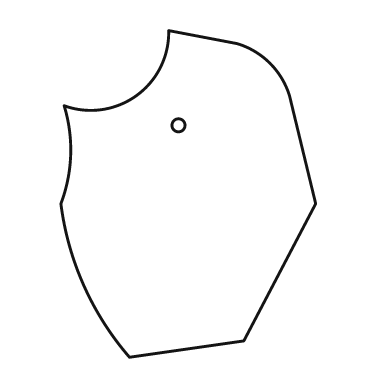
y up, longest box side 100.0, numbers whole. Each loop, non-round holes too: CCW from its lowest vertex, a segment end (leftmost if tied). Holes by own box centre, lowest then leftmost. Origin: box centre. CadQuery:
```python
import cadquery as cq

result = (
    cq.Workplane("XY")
    .moveTo(-18.0, -50.0)
    .lineTo(17.0, -45.0)
    .lineTo(39.0, -3.0)
    .lineTo(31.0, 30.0)
    .threePointArc((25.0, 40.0), (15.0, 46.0))
    .lineTo(-6.0, 50.0)
    .threePointArc((-16.0, 30.0), (-38.0, 27.0))
    .threePointArc((-36.0, 12.0), (-39.0, -3.0))
    .threePointArc((-32.0, -28.0), (-18.0, -50.0))
    .close()
    .moveTo(-3.0, 21.0)
    .circle(2.0)
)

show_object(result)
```